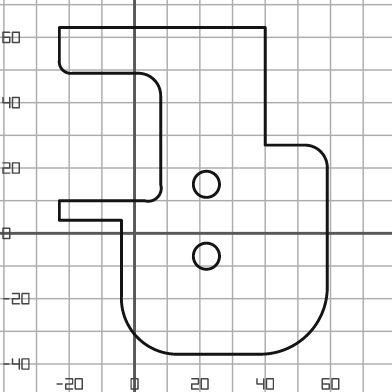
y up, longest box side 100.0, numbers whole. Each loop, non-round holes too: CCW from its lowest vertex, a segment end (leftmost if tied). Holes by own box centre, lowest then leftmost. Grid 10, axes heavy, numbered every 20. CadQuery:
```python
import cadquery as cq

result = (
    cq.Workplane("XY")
    .moveTo(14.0, -37.0)
    .lineTo(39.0, -37.0)
    .threePointArc((53.0, -31.0), (59.0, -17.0))
    .lineTo(59.0, 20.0)
    .threePointArc((57.0, 25.0), (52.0, 27.0))
    .lineTo(40.0, 27.0)
    .lineTo(40.0, 63.0)
    .lineTo(-23.0, 63.0)
    .lineTo(-23.0, 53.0)
    .threePointArc((-22.0, 50.0), (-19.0, 49.0))
    .lineTo(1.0, 49.0)
    .threePointArc((6.0, 47.0), (8.0, 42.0))
    .lineTo(8.0, 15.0)
    .threePointArc((7.0, 11.0), (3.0, 10.0))
    .lineTo(-23.0, 10.0)
    .lineTo(-23.0, 4.0)
    .lineTo(-4.0, 4.0)
    .lineTo(-4.0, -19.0)
    .threePointArc((1.0, -32.0), (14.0, -37.0))
    .close()
    .moveTo(22.0, -7.0)
    .circle(4.0)
    .moveTo(22.0, 15.0)
    .circle(4.0)
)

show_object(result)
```